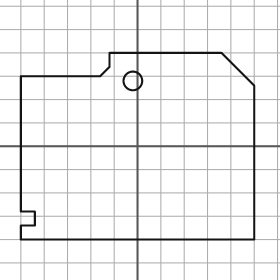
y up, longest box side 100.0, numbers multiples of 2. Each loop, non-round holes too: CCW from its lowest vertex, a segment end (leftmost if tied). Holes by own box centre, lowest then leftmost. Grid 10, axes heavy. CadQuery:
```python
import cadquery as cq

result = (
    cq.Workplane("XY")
    .moveTo(-50.0, -40.0)
    .lineTo(50.0, -40.0)
    .lineTo(50.0, 26.0)
    .lineTo(36.0, 40.0)
    .lineTo(-12.0, 40.0)
    .lineTo(-12.0, 34.0)
    .lineTo(-16.0, 30.0)
    .lineTo(-50.0, 30.0)
    .lineTo(-50.0, -28.0)
    .lineTo(-44.0, -28.0)
    .lineTo(-44.0, -34.0)
    .lineTo(-50.0, -34.0)
    .close()
    .moveTo(-2.0, 28.0)
    .circle(4.0)
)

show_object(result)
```